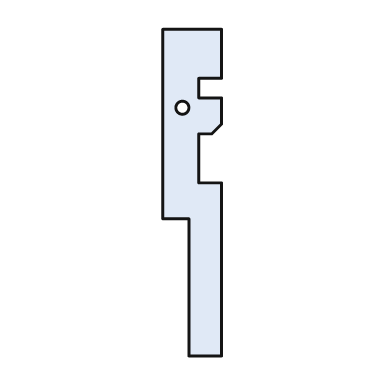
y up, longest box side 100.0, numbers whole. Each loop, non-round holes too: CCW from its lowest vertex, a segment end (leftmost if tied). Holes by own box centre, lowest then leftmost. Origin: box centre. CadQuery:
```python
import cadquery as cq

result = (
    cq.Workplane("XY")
    .moveTo(-1.0, -50.0)
    .lineTo(9.0, -50.0)
    .lineTo(9.0, 3.0)
    .lineTo(2.0, 3.0)
    .lineTo(2.0, 18.0)
    .lineTo(6.0, 18.0)
    .lineTo(9.0, 21.0)
    .lineTo(9.0, 29.0)
    .lineTo(2.0, 29.0)
    .lineTo(2.0, 35.0)
    .lineTo(9.0, 35.0)
    .lineTo(9.0, 50.0)
    .lineTo(-9.0, 50.0)
    .lineTo(-9.0, -8.0)
    .lineTo(-1.0, -8.0)
    .close()
    .moveTo(-3.0, 26.0)
    .circle(2.0)
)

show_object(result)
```